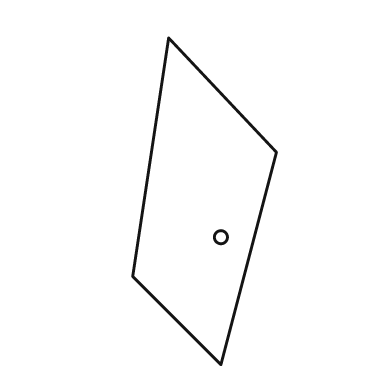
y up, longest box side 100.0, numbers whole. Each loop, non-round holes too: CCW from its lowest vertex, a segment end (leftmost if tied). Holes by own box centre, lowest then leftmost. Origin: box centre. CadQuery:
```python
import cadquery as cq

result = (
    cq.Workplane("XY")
    .moveTo(5.0, -50.0)
    .lineTo(22.0, 15.0)
    .lineTo(-11.0, 50.0)
    .lineTo(-22.0, -23.0)
    .close()
    .moveTo(5.0, -11.0)
    .circle(2.0)
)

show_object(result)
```